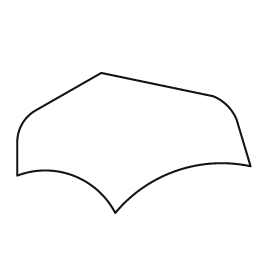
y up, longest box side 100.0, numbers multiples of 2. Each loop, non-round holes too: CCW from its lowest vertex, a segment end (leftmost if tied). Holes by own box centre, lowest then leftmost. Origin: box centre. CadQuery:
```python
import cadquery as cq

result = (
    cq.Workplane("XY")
    .moveTo(-8.0, -30.0)
    .threePointArc((18.0, -12.0), (50.0, -10.0))
    .lineTo(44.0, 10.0)
    .threePointArc((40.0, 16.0), (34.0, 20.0))
    .lineTo(-14.0, 30.0)
    .lineTo(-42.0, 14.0)
    .threePointArc((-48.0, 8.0), (-50.0, 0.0))
    .lineTo(-50.0, -14.0)
    .threePointArc((-26.0, -14.0), (-8.0, -30.0))
    .close()
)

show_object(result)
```